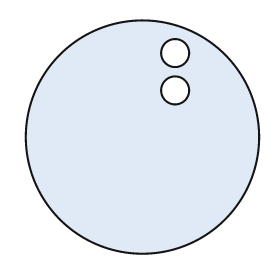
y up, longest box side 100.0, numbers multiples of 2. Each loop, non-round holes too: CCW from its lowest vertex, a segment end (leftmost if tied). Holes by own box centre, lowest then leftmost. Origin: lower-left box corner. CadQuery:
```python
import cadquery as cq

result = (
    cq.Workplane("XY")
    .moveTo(50.0, 50.0)
    .circle(50.0)
    .moveTo(64.0, 70.0)
    .circle(6.0)
    .moveTo(64.0, 86.0)
    .circle(6.0)
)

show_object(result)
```